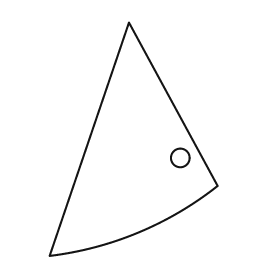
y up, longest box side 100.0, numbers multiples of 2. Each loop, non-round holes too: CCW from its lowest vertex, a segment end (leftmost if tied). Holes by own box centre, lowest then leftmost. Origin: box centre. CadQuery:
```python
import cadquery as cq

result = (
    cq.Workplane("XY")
    .moveTo(-36.0, -50.0)
    .threePointArc((2.0, -40.0), (36.0, -20.0))
    .lineTo(-2.0, 50.0)
    .close()
    .moveTo(20.0, -8.0)
    .circle(4.0)
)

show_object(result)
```